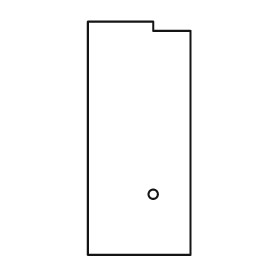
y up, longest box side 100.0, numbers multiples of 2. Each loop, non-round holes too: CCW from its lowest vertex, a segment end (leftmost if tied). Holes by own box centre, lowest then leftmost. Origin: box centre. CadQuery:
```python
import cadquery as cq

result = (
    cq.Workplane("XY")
    .moveTo(-22.0, -50.0)
    .lineTo(22.0, -50.0)
    .lineTo(22.0, 46.0)
    .lineTo(6.0, 46.0)
    .lineTo(6.0, 50.0)
    .lineTo(-22.0, 50.0)
    .close()
    .moveTo(6.0, -24.0)
    .circle(2.0)
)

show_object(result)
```